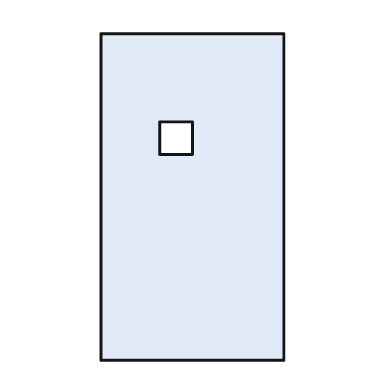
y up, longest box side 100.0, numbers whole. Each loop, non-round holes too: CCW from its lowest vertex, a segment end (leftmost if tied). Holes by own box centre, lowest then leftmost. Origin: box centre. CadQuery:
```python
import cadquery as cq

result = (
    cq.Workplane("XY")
    .moveTo(-28.0, -50.0)
    .lineTo(28.0, -50.0)
    .lineTo(28.0, 50.0)
    .lineTo(-28.0, 50.0)
    .close()
    .moveTo(-10.0, 13.0)
    .lineTo(0.0, 13.0)
    .lineTo(0.0, 23.0)
    .lineTo(-10.0, 23.0)
    .close()
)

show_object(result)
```